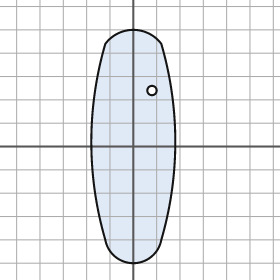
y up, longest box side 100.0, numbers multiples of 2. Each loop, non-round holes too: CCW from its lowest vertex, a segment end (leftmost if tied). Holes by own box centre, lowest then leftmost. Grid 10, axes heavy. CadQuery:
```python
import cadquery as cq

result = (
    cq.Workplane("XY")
    .moveTo(-12.0, -40.0)
    .threePointArc((0.0, -50.0), (12.0, -40.0))
    .threePointArc((18.0, 2.0), (12.0, 44.0))
    .threePointArc((0.0, 50.0), (-12.0, 44.0))
    .threePointArc((-18.0, 2.0), (-12.0, -40.0))
    .close()
    .moveTo(8.0, 24.0)
    .circle(2.0)
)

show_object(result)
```